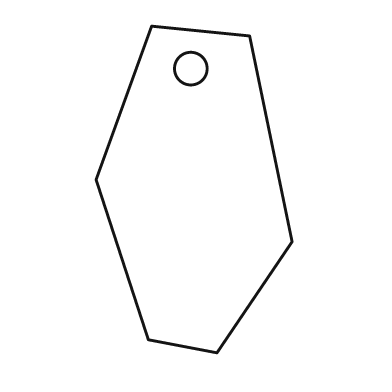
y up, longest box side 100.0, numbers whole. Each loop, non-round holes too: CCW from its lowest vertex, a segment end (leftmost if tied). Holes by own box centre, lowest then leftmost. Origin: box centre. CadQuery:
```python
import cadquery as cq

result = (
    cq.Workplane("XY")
    .moveTo(7.0, -50.0)
    .lineTo(30.0, -16.0)
    .lineTo(17.0, 47.0)
    .lineTo(-13.0, 50.0)
    .lineTo(-30.0, 3.0)
    .lineTo(-14.0, -46.0)
    .close()
    .moveTo(-1.0, 37.0)
    .circle(5.0)
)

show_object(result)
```